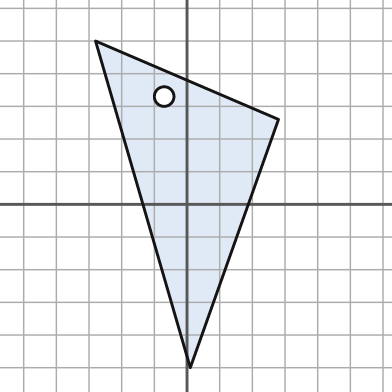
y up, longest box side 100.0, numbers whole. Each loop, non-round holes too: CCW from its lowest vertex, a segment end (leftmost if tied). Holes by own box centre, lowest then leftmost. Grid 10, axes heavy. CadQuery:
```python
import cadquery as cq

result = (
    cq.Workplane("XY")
    .moveTo(1.0, -50.0)
    .lineTo(28.0, 26.0)
    .lineTo(-28.0, 50.0)
    .close()
    .moveTo(-7.0, 33.0)
    .circle(3.0)
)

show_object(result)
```